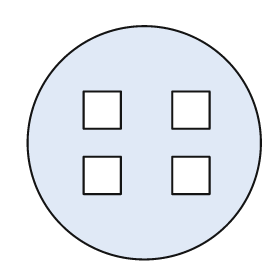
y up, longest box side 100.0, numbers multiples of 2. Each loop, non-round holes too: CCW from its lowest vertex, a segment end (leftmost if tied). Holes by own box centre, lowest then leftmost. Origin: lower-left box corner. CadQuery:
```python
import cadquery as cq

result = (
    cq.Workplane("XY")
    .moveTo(50.0, 50.0)
    .circle(50.0)
    .moveTo(24.0, 28.0)
    .lineTo(40.0, 28.0)
    .lineTo(40.0, 44.0)
    .lineTo(24.0, 44.0)
    .close()
    .moveTo(62.0, 28.0)
    .lineTo(78.0, 28.0)
    .lineTo(78.0, 44.0)
    .lineTo(62.0, 44.0)
    .close()
    .moveTo(24.0, 56.0)
    .lineTo(40.0, 56.0)
    .lineTo(40.0, 72.0)
    .lineTo(24.0, 72.0)
    .close()
    .moveTo(62.0, 56.0)
    .lineTo(78.0, 56.0)
    .lineTo(78.0, 72.0)
    .lineTo(62.0, 72.0)
    .close()
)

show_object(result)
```